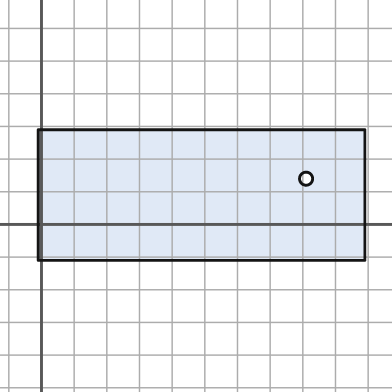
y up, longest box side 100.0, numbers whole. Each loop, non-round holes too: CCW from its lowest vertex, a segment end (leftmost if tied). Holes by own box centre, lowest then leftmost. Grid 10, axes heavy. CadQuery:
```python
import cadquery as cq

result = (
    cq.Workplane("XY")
    .moveTo(-1.0, -11.0)
    .lineTo(99.0, -11.0)
    .lineTo(99.0, 29.0)
    .lineTo(-1.0, 29.0)
    .close()
    .moveTo(81.0, 14.0)
    .circle(2.0)
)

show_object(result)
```